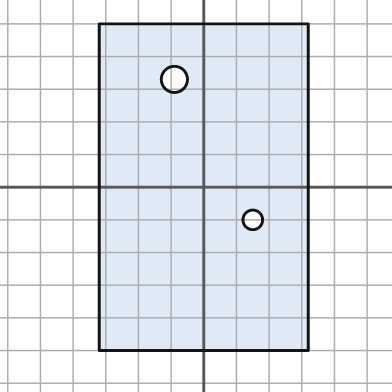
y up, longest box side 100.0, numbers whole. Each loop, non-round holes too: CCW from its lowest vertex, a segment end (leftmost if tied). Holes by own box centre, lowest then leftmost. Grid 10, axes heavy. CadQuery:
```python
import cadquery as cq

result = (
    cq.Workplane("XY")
    .moveTo(-32.0, -50.0)
    .lineTo(32.0, -50.0)
    .lineTo(32.0, 50.0)
    .lineTo(-32.0, 50.0)
    .close()
    .moveTo(15.0, -10.0)
    .circle(3.0)
    .moveTo(-9.0, 33.0)
    .circle(4.0)
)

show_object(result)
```